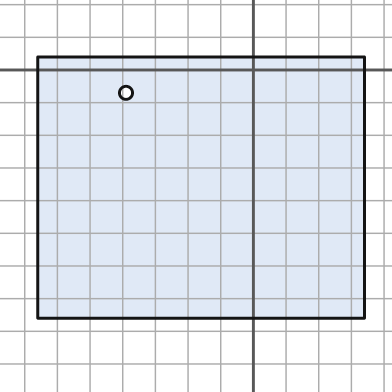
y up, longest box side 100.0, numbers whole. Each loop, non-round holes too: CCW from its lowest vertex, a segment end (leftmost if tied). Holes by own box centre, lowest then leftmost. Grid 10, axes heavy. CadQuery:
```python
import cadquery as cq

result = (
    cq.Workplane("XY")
    .moveTo(-66.0, -76.0)
    .lineTo(34.0, -76.0)
    .lineTo(34.0, 4.0)
    .lineTo(-66.0, 4.0)
    .close()
    .moveTo(-39.0, -7.0)
    .circle(2.0)
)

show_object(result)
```